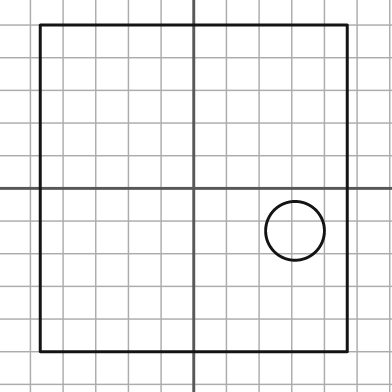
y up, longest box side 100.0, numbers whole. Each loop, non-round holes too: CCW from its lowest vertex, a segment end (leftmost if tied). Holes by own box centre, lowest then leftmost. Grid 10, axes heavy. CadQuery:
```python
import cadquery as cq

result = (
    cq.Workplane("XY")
    .moveTo(-47.0, -50.0)
    .lineTo(47.0, -50.0)
    .lineTo(47.0, 50.0)
    .lineTo(-47.0, 50.0)
    .close()
    .moveTo(31.0, -13.0)
    .circle(9.0)
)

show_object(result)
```